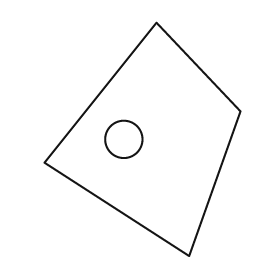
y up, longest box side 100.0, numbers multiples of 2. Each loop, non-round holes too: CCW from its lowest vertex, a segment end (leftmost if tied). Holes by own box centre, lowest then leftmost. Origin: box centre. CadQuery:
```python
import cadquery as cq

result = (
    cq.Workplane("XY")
    .moveTo(20.0, -50.0)
    .lineTo(42.0, 12.0)
    .lineTo(6.0, 50.0)
    .lineTo(-42.0, -10.0)
    .close()
    .moveTo(-8.0, 0.0)
    .circle(8.0)
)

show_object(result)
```